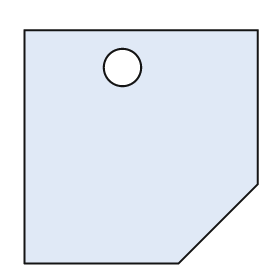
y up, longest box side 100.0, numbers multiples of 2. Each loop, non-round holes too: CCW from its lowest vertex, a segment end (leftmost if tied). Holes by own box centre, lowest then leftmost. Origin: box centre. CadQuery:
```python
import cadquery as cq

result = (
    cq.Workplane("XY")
    .moveTo(-50.0, -50.0)
    .lineTo(16.0, -50.0)
    .lineTo(50.0, -16.0)
    .lineTo(50.0, 50.0)
    .lineTo(-50.0, 50.0)
    .close()
    .moveTo(-8.0, 34.0)
    .circle(8.0)
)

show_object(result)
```